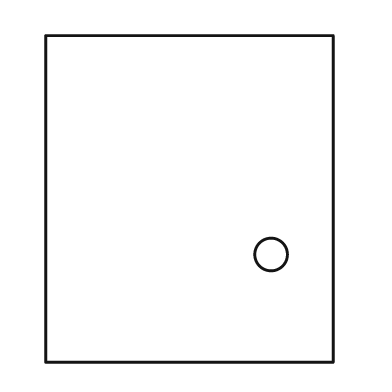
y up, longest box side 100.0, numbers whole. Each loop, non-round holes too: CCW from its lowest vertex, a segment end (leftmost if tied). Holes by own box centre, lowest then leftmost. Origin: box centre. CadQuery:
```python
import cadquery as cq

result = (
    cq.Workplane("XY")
    .moveTo(-44.0, -50.0)
    .lineTo(44.0, -50.0)
    .lineTo(44.0, 50.0)
    .lineTo(-44.0, 50.0)
    .close()
    .moveTo(25.0, -17.0)
    .circle(5.0)
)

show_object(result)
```